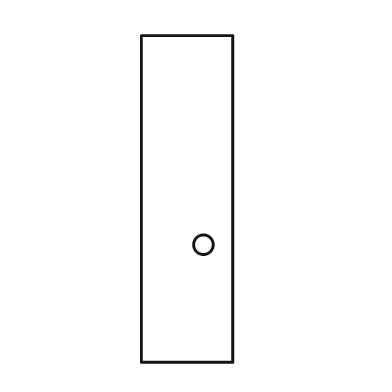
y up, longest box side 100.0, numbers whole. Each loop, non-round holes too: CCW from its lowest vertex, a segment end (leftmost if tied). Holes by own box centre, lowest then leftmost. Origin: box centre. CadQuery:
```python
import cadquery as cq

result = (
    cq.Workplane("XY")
    .moveTo(-14.0, -50.0)
    .lineTo(14.0, -50.0)
    .lineTo(14.0, 50.0)
    .lineTo(-14.0, 50.0)
    .close()
    .moveTo(5.0, -14.0)
    .circle(3.0)
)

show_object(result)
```